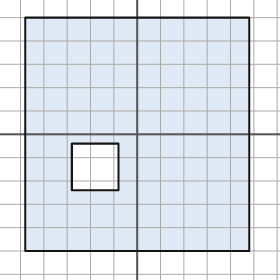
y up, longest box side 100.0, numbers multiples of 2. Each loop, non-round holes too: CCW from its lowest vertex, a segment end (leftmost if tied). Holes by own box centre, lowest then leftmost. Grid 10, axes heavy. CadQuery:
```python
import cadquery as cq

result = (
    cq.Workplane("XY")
    .moveTo(-48.0, -50.0)
    .lineTo(48.0, -50.0)
    .lineTo(48.0, 50.0)
    .lineTo(-48.0, 50.0)
    .close()
    .moveTo(-28.0, -24.0)
    .lineTo(-8.0, -24.0)
    .lineTo(-8.0, -4.0)
    .lineTo(-28.0, -4.0)
    .close()
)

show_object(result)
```